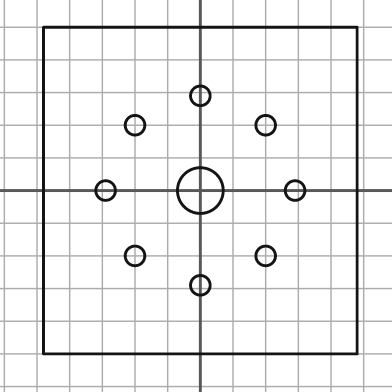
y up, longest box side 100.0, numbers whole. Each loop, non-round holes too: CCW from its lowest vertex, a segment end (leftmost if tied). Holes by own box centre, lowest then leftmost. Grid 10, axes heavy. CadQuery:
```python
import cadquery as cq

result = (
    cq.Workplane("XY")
    .moveTo(-48.0, -50.0)
    .lineTo(48.0, -50.0)
    .lineTo(48.0, 50.0)
    .lineTo(-48.0, 50.0)
    .close()
    .moveTo(0.0, -29.0)
    .circle(3.0)
    .moveTo(-20.0, -20.0)
    .circle(3.0)
    .moveTo(20.0, -20.0)
    .circle(3.0)
    .moveTo(-29.0, 0.0)
    .circle(3.0)
    .moveTo(0.0, 0.0)
    .circle(7.0)
    .moveTo(29.0, 0.0)
    .circle(3.0)
    .moveTo(-20.0, 20.0)
    .circle(3.0)
    .moveTo(20.0, 20.0)
    .circle(3.0)
    .moveTo(0.0, 29.0)
    .circle(3.0)
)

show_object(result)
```